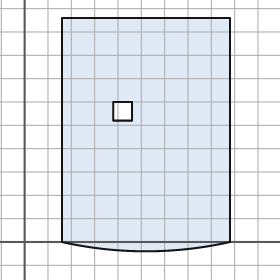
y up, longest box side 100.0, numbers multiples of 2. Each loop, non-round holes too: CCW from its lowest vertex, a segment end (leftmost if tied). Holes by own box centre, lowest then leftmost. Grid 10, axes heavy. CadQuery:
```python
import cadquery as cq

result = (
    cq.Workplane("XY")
    .moveTo(16.0, 0.0)
    .threePointArc((52.0, -4.0), (88.0, 0.0))
    .lineTo(88.0, 96.0)
    .lineTo(16.0, 96.0)
    .close()
    .moveTo(38.0, 52.0)
    .lineTo(46.0, 52.0)
    .lineTo(46.0, 60.0)
    .lineTo(38.0, 60.0)
    .close()
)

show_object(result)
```